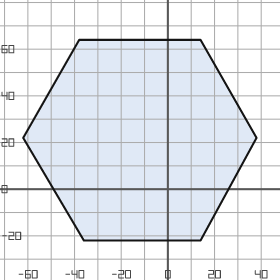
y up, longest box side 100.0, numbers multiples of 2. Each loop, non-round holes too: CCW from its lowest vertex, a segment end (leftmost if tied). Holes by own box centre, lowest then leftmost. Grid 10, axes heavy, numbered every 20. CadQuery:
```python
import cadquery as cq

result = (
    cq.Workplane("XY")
    .moveTo(-36.0, -22.0)
    .lineTo(14.0, -22.0)
    .lineTo(38.0, 22.0)
    .lineTo(14.0, 64.0)
    .lineTo(-38.0, 64.0)
    .lineTo(-62.0, 22.0)
    .close()
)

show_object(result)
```